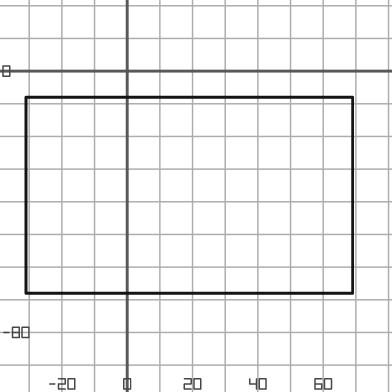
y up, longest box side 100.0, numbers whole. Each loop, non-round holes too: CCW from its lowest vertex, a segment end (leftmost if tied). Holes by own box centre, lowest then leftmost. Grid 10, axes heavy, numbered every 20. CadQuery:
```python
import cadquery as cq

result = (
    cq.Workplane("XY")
    .moveTo(-31.0, -68.0)
    .lineTo(69.0, -68.0)
    .lineTo(69.0, -8.0)
    .lineTo(-31.0, -8.0)
    .close()
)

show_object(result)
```